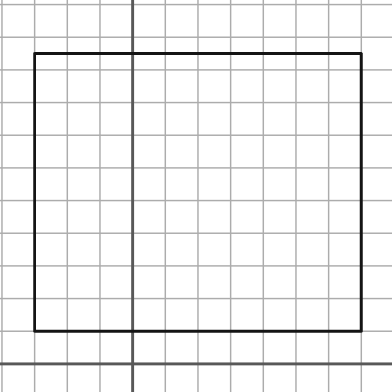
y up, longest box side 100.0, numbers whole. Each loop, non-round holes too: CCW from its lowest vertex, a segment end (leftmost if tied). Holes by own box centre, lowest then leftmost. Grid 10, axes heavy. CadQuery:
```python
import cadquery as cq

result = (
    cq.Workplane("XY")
    .moveTo(-30.0, 10.0)
    .lineTo(70.0, 10.0)
    .lineTo(70.0, 95.0)
    .lineTo(-30.0, 95.0)
    .close()
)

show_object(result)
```